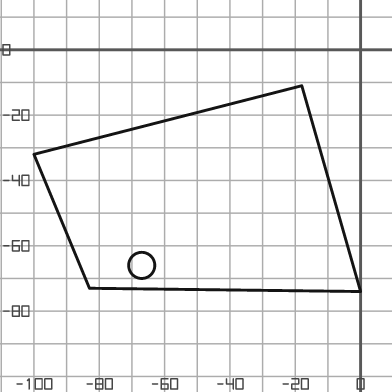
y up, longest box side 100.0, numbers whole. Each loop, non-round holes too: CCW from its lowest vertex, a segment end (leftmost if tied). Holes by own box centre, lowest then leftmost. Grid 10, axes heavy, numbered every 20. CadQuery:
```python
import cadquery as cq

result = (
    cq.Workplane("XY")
    .moveTo(0.0, -74.0)
    .lineTo(-18.0, -11.0)
    .lineTo(-100.0, -32.0)
    .lineTo(-83.0, -73.0)
    .close()
    .moveTo(-67.0, -66.0)
    .circle(4.0)
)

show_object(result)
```